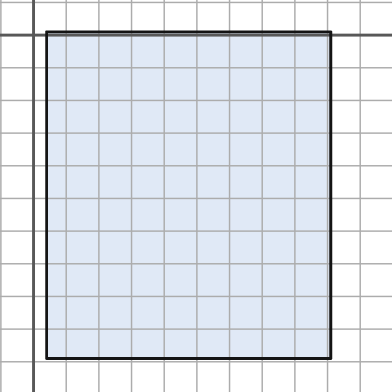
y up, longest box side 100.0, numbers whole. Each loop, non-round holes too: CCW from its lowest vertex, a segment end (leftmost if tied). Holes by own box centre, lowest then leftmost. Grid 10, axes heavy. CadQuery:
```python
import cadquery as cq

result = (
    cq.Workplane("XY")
    .moveTo(4.0, -99.0)
    .lineTo(91.0, -99.0)
    .lineTo(91.0, 1.0)
    .lineTo(4.0, 1.0)
    .close()
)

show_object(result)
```